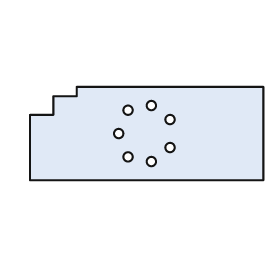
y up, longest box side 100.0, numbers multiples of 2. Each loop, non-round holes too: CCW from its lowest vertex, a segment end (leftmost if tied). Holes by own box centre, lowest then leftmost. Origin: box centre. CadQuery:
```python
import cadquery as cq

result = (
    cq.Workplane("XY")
    .moveTo(-50.0, -20.0)
    .lineTo(50.0, -20.0)
    .lineTo(50.0, 20.0)
    .lineTo(-30.0, 20.0)
    .lineTo(-30.0, 16.0)
    .lineTo(-40.0, 16.0)
    .lineTo(-40.0, 8.0)
    .lineTo(-50.0, 8.0)
    .close()
    .moveTo(2.0, -12.0)
    .circle(2.0)
    .moveTo(-8.0, -10.0)
    .circle(2.0)
    .moveTo(10.0, -6.0)
    .circle(2.0)
    .moveTo(-12.0, 0.0)
    .circle(2.0)
    .moveTo(10.0, 6.0)
    .circle(2.0)
    .moveTo(-8.0, 10.0)
    .circle(2.0)
    .moveTo(2.0, 12.0)
    .circle(2.0)
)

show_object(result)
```